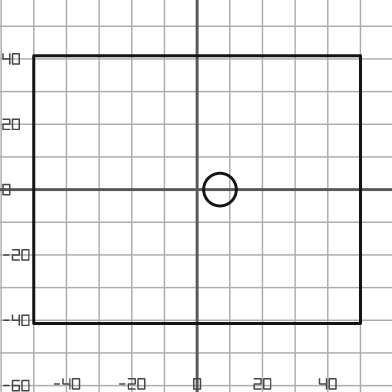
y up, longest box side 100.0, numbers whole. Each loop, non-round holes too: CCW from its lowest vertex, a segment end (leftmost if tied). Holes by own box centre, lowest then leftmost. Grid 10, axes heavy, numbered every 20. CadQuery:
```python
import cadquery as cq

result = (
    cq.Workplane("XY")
    .moveTo(-50.0, -41.0)
    .lineTo(50.0, -41.0)
    .lineTo(50.0, 41.0)
    .lineTo(-50.0, 41.0)
    .close()
    .moveTo(7.0, 0.0)
    .circle(5.0)
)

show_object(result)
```